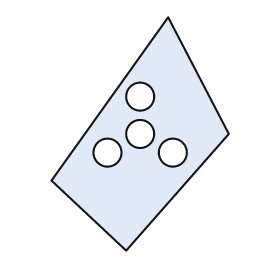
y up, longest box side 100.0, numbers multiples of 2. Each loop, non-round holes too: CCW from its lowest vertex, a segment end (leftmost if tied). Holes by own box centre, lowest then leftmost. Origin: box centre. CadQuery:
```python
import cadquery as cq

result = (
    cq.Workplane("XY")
    .moveTo(-6.0, -50.0)
    .lineTo(38.0, 0.0)
    .lineTo(12.0, 50.0)
    .lineTo(-38.0, -20.0)
    .close()
    .moveTo(-14.0, -8.0)
    .circle(6.0)
    .moveTo(14.0, -8.0)
    .circle(6.0)
    .moveTo(0.0, 0.0)
    .circle(6.0)
    .moveTo(0.0, 16.0)
    .circle(6.0)
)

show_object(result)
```